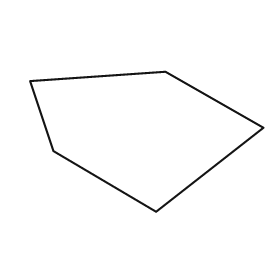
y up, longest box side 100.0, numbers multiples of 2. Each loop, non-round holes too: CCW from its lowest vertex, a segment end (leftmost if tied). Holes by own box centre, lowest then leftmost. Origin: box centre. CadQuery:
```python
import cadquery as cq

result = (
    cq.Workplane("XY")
    .moveTo(4.0, -30.0)
    .lineTo(50.0, 6.0)
    .lineTo(8.0, 30.0)
    .lineTo(-50.0, 26.0)
    .lineTo(-40.0, -4.0)
    .close()
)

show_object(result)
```